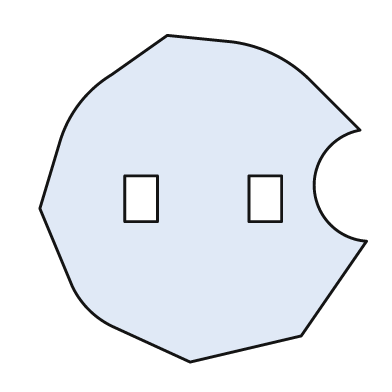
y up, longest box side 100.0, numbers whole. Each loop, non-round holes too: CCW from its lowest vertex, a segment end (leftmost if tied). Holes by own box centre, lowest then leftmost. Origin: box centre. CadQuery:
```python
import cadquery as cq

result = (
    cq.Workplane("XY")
    .moveTo(-4.0, -50.0)
    .lineTo(30.0, -42.0)
    .lineTo(50.0, -13.0)
    .threePointArc((34.0, 3.0), (48.0, 21.0))
    .lineTo(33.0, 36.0)
    .threePointArc((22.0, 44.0), (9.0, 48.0))
    .lineTo(-11.0, 50.0)
    .lineTo(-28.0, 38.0)
    .threePointArc((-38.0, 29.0), (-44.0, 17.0))
    .lineTo(-50.0, -3.0)
    .lineTo(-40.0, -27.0)
    .threePointArc((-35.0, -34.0), (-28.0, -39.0))
    .close()
    .moveTo(-24.0, -7.0)
    .lineTo(-14.0, -7.0)
    .lineTo(-14.0, 7.0)
    .lineTo(-24.0, 7.0)
    .close()
    .moveTo(14.0, -7.0)
    .lineTo(24.0, -7.0)
    .lineTo(24.0, 7.0)
    .lineTo(14.0, 7.0)
    .close()
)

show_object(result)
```